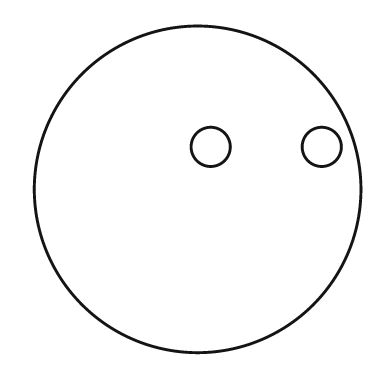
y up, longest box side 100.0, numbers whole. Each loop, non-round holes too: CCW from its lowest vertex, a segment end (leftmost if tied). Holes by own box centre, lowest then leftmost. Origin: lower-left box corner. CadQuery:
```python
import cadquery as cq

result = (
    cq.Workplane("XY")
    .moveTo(50.0, 50.0)
    .circle(50.0)
    .moveTo(54.0, 63.0)
    .circle(6.0)
    .moveTo(88.0, 63.0)
    .circle(6.0)
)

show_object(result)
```